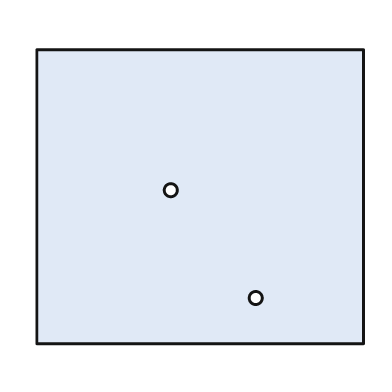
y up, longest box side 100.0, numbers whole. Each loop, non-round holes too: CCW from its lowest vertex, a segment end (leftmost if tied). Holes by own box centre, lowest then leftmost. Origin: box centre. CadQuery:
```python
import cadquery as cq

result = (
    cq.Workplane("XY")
    .moveTo(-50.0, -45.0)
    .lineTo(50.0, -45.0)
    .lineTo(50.0, 45.0)
    .lineTo(-50.0, 45.0)
    .close()
    .moveTo(17.0, -31.0)
    .circle(2.0)
    .moveTo(-9.0, 2.0)
    .circle(2.0)
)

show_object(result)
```